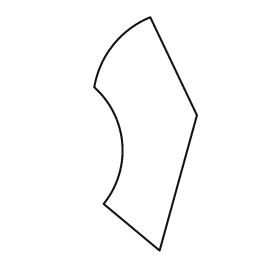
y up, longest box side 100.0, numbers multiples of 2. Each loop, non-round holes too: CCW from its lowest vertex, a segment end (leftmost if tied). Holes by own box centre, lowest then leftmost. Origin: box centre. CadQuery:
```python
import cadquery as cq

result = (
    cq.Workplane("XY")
    .moveTo(6.0, -50.0)
    .lineTo(22.0, 8.0)
    .lineTo(2.0, 50.0)
    .threePointArc((-14.0, 38.0), (-22.0, 20.0))
    .threePointArc((-10.0, -4.0), (-18.0, -30.0))
    .close()
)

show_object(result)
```